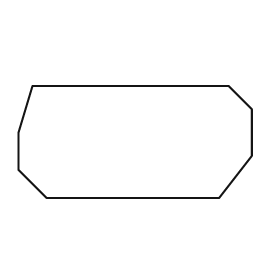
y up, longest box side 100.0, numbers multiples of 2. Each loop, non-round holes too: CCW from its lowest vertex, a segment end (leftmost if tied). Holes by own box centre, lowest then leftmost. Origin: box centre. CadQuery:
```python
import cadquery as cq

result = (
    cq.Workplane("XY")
    .moveTo(-38.0, -24.0)
    .lineTo(36.0, -24.0)
    .lineTo(50.0, -6.0)
    .lineTo(50.0, 14.0)
    .lineTo(40.0, 24.0)
    .lineTo(-44.0, 24.0)
    .lineTo(-50.0, 4.0)
    .lineTo(-50.0, -12.0)
    .close()
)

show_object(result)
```